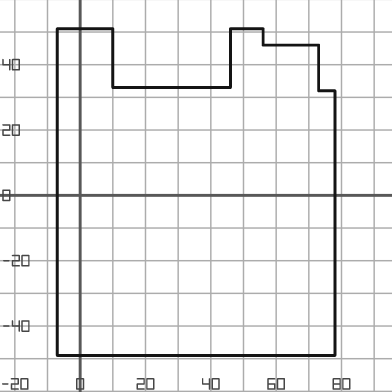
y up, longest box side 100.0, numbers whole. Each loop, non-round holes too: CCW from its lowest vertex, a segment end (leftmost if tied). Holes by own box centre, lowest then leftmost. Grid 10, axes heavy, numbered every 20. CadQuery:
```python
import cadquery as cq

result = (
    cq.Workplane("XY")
    .moveTo(-7.0, -49.0)
    .lineTo(78.0, -49.0)
    .lineTo(78.0, 32.0)
    .lineTo(73.0, 32.0)
    .lineTo(73.0, 46.0)
    .lineTo(56.0, 46.0)
    .lineTo(56.0, 51.0)
    .lineTo(46.0, 51.0)
    .lineTo(46.0, 33.0)
    .lineTo(10.0, 33.0)
    .lineTo(10.0, 51.0)
    .lineTo(-7.0, 51.0)
    .close()
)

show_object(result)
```